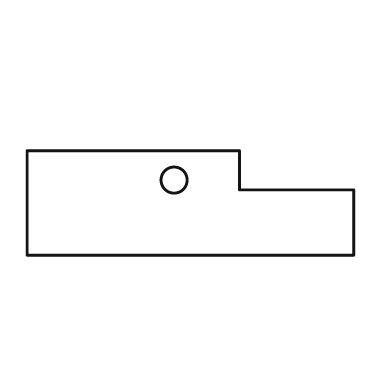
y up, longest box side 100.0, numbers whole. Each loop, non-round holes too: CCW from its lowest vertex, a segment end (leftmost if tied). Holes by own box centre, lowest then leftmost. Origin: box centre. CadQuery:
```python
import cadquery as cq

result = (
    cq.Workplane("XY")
    .moveTo(-50.0, -16.0)
    .lineTo(50.0, -16.0)
    .lineTo(50.0, 4.0)
    .lineTo(15.0, 4.0)
    .lineTo(15.0, 16.0)
    .lineTo(-50.0, 16.0)
    .close()
    .moveTo(-5.0, 7.0)
    .circle(4.0)
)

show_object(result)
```